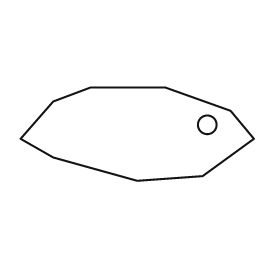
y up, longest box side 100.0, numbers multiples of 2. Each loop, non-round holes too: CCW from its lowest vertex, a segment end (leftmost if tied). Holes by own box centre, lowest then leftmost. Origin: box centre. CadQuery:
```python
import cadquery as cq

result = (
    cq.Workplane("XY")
    .moveTo(0.0, -20.0)
    .lineTo(28.0, -18.0)
    .lineTo(50.0, -2.0)
    .lineTo(40.0, 10.0)
    .lineTo(12.0, 20.0)
    .lineTo(-20.0, 20.0)
    .lineTo(-36.0, 14.0)
    .lineTo(-50.0, -2.0)
    .lineTo(-36.0, -10.0)
    .close()
    .moveTo(30.0, 4.0)
    .circle(4.0)
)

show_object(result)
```